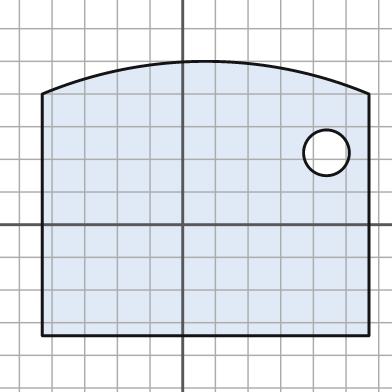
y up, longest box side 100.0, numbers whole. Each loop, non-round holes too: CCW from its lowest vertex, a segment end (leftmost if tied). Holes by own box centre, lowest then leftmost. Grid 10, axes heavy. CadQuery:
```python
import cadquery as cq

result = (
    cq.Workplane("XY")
    .moveTo(-43.0, -34.0)
    .lineTo(57.0, -34.0)
    .lineTo(57.0, 40.0)
    .threePointArc((7.0, 50.0), (-43.0, 40.0))
    .close()
    .moveTo(44.0, 22.0)
    .circle(7.0)
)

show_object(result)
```